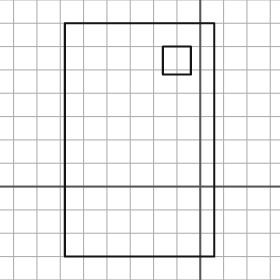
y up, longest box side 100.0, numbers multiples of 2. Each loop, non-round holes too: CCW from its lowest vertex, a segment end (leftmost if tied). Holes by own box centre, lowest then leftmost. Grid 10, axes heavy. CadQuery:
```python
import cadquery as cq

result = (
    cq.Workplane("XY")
    .moveTo(-58.0, -30.0)
    .lineTo(6.0, -30.0)
    .lineTo(6.0, 70.0)
    .lineTo(-58.0, 70.0)
    .close()
    .moveTo(-16.0, 48.0)
    .lineTo(-4.0, 48.0)
    .lineTo(-4.0, 60.0)
    .lineTo(-16.0, 60.0)
    .close()
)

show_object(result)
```